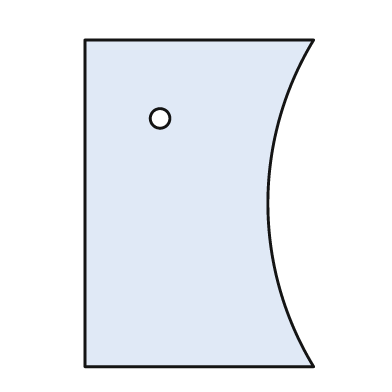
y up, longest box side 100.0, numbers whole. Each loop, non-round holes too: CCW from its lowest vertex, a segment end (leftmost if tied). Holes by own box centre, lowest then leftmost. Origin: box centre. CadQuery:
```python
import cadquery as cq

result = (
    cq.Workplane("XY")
    .moveTo(-35.0, -50.0)
    .lineTo(35.0, -50.0)
    .threePointArc((21.0, 0.0), (35.0, 50.0))
    .lineTo(-35.0, 50.0)
    .close()
    .moveTo(-12.0, 26.0)
    .circle(3.0)
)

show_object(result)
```